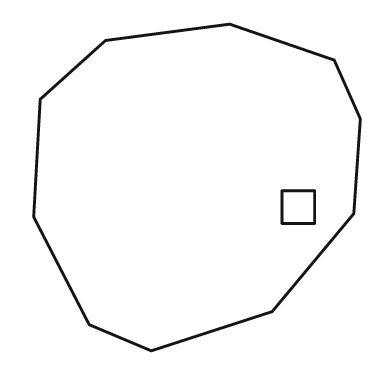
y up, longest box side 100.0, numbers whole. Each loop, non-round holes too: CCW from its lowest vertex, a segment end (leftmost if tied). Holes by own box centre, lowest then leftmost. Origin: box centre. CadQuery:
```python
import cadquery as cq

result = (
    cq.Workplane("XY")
    .moveTo(-14.0, -50.0)
    .lineTo(23.0, -38.0)
    .lineTo(48.0, -8.0)
    .lineTo(50.0, 21.0)
    .lineTo(42.0, 39.0)
    .lineTo(10.0, 50.0)
    .lineTo(-28.0, 45.0)
    .lineTo(-48.0, 27.0)
    .lineTo(-50.0, -9.0)
    .lineTo(-33.0, -42.0)
    .close()
    .moveTo(26.0, -11.0)
    .lineTo(36.0, -11.0)
    .lineTo(36.0, -1.0)
    .lineTo(26.0, -1.0)
    .close()
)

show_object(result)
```